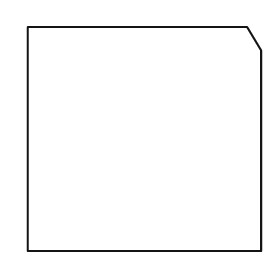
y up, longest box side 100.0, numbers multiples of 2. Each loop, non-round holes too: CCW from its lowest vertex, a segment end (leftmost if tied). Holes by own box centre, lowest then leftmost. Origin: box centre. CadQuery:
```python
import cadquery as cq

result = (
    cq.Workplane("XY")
    .moveTo(-50.0, -48.0)
    .lineTo(50.0, -48.0)
    .lineTo(50.0, 38.0)
    .lineTo(44.0, 48.0)
    .lineTo(-50.0, 48.0)
    .close()
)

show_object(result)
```